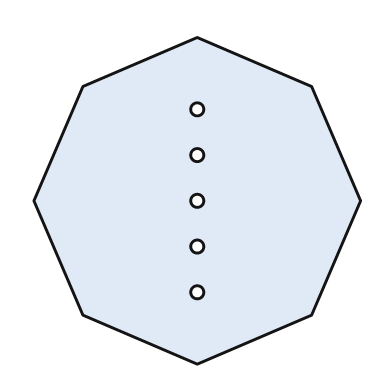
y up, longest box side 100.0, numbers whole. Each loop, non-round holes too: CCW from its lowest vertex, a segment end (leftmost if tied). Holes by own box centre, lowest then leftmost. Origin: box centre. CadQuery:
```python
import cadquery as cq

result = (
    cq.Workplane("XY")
    .moveTo(0.0, -50.0)
    .lineTo(35.0, -35.0)
    .lineTo(50.0, 0.0)
    .lineTo(35.0, 35.0)
    .lineTo(0.0, 50.0)
    .lineTo(-35.0, 35.0)
    .lineTo(-50.0, 0.0)
    .lineTo(-35.0, -35.0)
    .close()
    .moveTo(0.0, -28.0)
    .circle(2.0)
    .moveTo(0.0, -14.0)
    .circle(2.0)
    .moveTo(0.0, 0.0)
    .circle(2.0)
    .moveTo(0.0, 14.0)
    .circle(2.0)
    .moveTo(0.0, 28.0)
    .circle(2.0)
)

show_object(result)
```